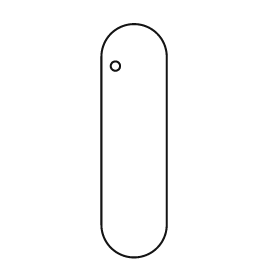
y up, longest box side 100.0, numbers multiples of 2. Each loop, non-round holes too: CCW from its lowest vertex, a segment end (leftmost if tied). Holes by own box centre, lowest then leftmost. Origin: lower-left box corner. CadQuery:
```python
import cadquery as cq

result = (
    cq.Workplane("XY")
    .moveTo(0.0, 14.0)
    .threePointArc((14.0, 0.0), (28.0, 14.0))
    .lineTo(28.0, 86.0)
    .threePointArc((14.0, 100.0), (0.0, 86.0))
    .close()
    .moveTo(6.0, 82.0)
    .circle(2.0)
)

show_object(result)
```